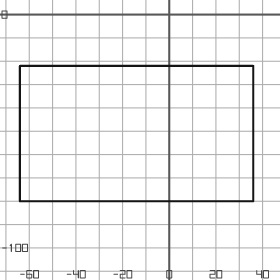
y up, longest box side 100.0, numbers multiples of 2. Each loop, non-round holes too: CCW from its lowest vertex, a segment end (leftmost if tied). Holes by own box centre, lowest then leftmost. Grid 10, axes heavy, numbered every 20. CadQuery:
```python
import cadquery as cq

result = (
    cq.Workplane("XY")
    .moveTo(-64.0, -80.0)
    .lineTo(36.0, -80.0)
    .lineTo(36.0, -22.0)
    .lineTo(-64.0, -22.0)
    .close()
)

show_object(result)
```